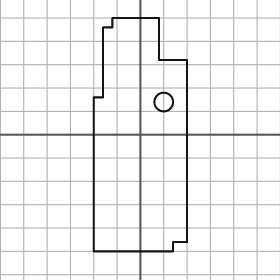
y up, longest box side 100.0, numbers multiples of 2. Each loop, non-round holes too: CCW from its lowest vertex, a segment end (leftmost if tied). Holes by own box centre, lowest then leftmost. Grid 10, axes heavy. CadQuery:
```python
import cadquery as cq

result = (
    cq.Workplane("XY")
    .moveTo(-20.0, -50.0)
    .lineTo(14.0, -50.0)
    .lineTo(14.0, -46.0)
    .lineTo(20.0, -46.0)
    .lineTo(20.0, 32.0)
    .lineTo(8.0, 32.0)
    .lineTo(8.0, 50.0)
    .lineTo(-12.0, 50.0)
    .lineTo(-12.0, 46.0)
    .lineTo(-16.0, 46.0)
    .lineTo(-16.0, 16.0)
    .lineTo(-20.0, 16.0)
    .close()
    .moveTo(10.0, 14.0)
    .circle(4.0)
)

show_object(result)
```